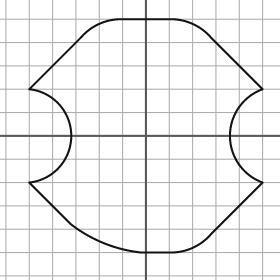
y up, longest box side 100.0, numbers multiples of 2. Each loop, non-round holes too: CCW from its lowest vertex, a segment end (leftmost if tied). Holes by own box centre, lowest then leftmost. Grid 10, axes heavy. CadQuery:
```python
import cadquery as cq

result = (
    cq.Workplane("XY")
    .moveTo(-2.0, -50.0)
    .lineTo(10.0, -50.0)
    .threePointArc((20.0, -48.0), (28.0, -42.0))
    .lineTo(50.0, -20.0)
    .threePointArc((36.0, 0.0), (50.0, 20.0))
    .lineTo(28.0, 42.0)
    .threePointArc((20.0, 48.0), (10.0, 50.0))
    .lineTo(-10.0, 50.0)
    .threePointArc((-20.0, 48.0), (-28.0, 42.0))
    .lineTo(-50.0, 20.0)
    .threePointArc((-32.0, 0.0), (-50.0, -20.0))
    .lineTo(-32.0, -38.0)
    .threePointArc((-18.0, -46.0), (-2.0, -50.0))
    .close()
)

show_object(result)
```